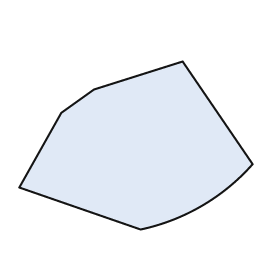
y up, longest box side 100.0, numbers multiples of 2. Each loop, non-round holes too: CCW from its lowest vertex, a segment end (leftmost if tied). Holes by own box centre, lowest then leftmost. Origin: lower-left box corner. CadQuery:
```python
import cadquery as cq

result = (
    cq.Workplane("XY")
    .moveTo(52.0, 0.0)
    .threePointArc((78.0, 10.0), (100.0, 28.0))
    .lineTo(70.0, 72.0)
    .lineTo(32.0, 60.0)
    .lineTo(18.0, 50.0)
    .lineTo(0.0, 18.0)
    .close()
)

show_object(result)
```